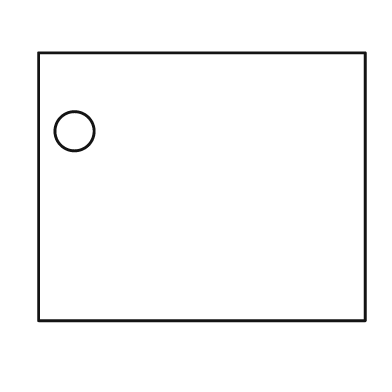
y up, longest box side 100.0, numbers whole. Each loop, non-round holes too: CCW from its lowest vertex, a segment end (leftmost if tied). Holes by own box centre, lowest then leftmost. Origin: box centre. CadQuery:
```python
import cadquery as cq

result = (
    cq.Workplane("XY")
    .moveTo(-50.0, -41.0)
    .lineTo(50.0, -41.0)
    .lineTo(50.0, 41.0)
    .lineTo(-50.0, 41.0)
    .close()
    .moveTo(-39.0, 17.0)
    .circle(6.0)
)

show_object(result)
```